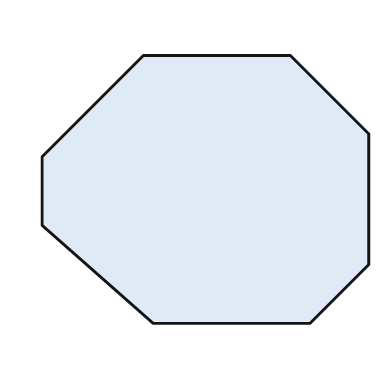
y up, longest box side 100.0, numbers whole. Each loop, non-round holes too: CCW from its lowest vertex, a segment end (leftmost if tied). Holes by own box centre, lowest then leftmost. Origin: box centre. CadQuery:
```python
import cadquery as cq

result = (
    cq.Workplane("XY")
    .moveTo(-16.0, -41.0)
    .lineTo(32.0, -41.0)
    .lineTo(50.0, -23.0)
    .lineTo(50.0, 17.0)
    .lineTo(26.0, 41.0)
    .lineTo(-19.0, 41.0)
    .lineTo(-50.0, 10.0)
    .lineTo(-50.0, -11.0)
    .close()
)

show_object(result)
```